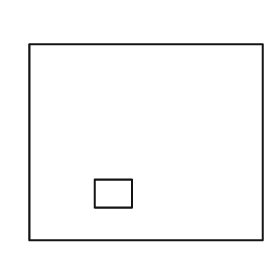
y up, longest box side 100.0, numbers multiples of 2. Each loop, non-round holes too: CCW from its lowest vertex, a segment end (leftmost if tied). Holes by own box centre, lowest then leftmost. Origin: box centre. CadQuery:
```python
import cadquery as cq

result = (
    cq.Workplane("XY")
    .moveTo(-50.0, -42.0)
    .lineTo(50.0, -42.0)
    .lineTo(50.0, 42.0)
    .lineTo(-50.0, 42.0)
    .close()
    .moveTo(-22.0, -28.0)
    .lineTo(-6.0, -28.0)
    .lineTo(-6.0, -16.0)
    .lineTo(-22.0, -16.0)
    .close()
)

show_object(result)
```